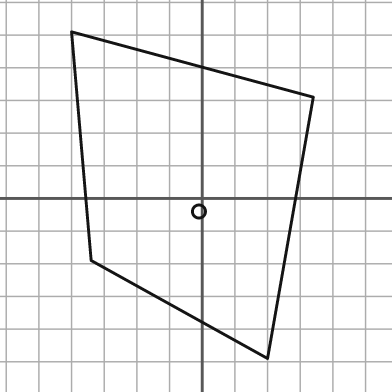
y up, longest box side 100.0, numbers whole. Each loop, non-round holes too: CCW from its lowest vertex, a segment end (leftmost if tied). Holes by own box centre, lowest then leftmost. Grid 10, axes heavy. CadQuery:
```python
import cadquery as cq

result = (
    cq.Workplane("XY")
    .moveTo(20.0, -49.0)
    .lineTo(34.0, 31.0)
    .lineTo(-40.0, 51.0)
    .lineTo(-34.0, -19.0)
    .close()
    .moveTo(-1.0, -4.0)
    .circle(2.0)
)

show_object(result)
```